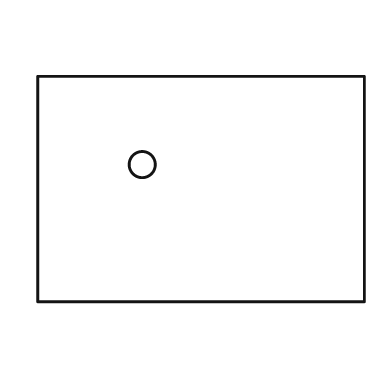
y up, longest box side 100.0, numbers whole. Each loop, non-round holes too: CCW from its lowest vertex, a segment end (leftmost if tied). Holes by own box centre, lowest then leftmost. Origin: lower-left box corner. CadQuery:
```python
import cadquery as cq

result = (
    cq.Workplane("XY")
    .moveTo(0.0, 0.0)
    .lineTo(100.0, 0.0)
    .lineTo(100.0, 69.0)
    .lineTo(0.0, 69.0)
    .close()
    .moveTo(32.0, 42.0)
    .circle(4.0)
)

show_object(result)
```